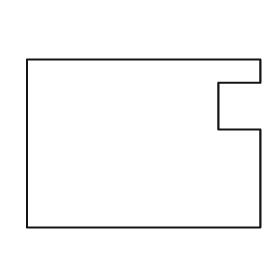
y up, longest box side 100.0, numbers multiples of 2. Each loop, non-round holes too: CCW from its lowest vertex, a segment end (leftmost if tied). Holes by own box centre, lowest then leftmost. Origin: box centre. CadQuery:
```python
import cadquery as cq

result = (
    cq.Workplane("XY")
    .moveTo(-50.0, -36.0)
    .lineTo(50.0, -36.0)
    .lineTo(50.0, 6.0)
    .lineTo(32.0, 6.0)
    .lineTo(32.0, 26.0)
    .lineTo(50.0, 26.0)
    .lineTo(50.0, 36.0)
    .lineTo(-50.0, 36.0)
    .close()
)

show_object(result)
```